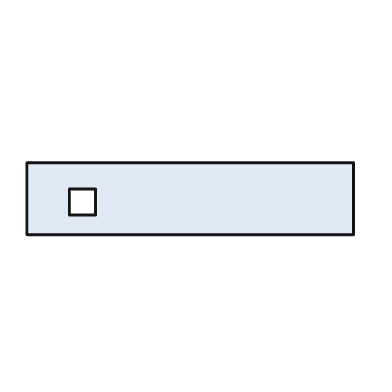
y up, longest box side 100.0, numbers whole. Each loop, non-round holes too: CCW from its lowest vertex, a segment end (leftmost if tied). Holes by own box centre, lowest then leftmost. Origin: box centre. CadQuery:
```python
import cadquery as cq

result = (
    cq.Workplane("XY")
    .moveTo(-50.0, -11.0)
    .lineTo(50.0, -11.0)
    .lineTo(50.0, 11.0)
    .lineTo(-50.0, 11.0)
    .close()
    .moveTo(-37.0, -5.0)
    .lineTo(-29.0, -5.0)
    .lineTo(-29.0, 3.0)
    .lineTo(-37.0, 3.0)
    .close()
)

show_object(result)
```